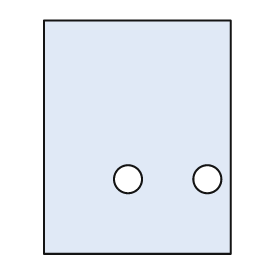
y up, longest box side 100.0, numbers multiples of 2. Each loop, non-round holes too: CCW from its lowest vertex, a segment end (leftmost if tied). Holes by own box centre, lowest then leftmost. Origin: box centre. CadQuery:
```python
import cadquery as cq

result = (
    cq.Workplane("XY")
    .moveTo(-40.0, -50.0)
    .lineTo(40.0, -50.0)
    .lineTo(40.0, 50.0)
    .lineTo(-40.0, 50.0)
    .close()
    .moveTo(-4.0, -18.0)
    .circle(6.0)
    .moveTo(30.0, -18.0)
    .circle(6.0)
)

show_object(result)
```